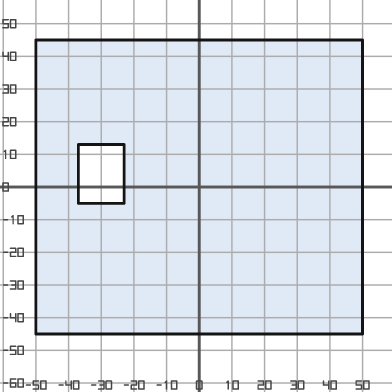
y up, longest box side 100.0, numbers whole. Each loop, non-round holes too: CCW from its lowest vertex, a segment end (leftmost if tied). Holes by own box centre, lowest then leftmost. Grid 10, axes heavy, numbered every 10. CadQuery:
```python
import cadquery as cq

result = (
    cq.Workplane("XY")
    .moveTo(-50.0, -45.0)
    .lineTo(50.0, -45.0)
    .lineTo(50.0, 45.0)
    .lineTo(-50.0, 45.0)
    .close()
    .moveTo(-37.0, -5.0)
    .lineTo(-23.0, -5.0)
    .lineTo(-23.0, 13.0)
    .lineTo(-37.0, 13.0)
    .close()
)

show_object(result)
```